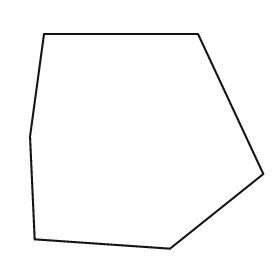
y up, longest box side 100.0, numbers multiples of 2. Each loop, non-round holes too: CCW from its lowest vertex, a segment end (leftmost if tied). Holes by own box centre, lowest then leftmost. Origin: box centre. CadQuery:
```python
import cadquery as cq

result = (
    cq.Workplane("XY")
    .moveTo(10.0, -46.0)
    .lineTo(50.0, -14.0)
    .lineTo(22.0, 46.0)
    .lineTo(-44.0, 46.0)
    .lineTo(-50.0, 2.0)
    .lineTo(-48.0, -42.0)
    .close()
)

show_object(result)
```